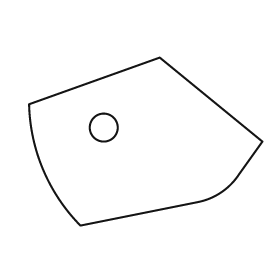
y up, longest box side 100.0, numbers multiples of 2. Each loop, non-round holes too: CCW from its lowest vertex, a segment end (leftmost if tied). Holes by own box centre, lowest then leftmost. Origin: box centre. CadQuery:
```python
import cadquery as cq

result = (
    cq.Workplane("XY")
    .moveTo(-28.0, -36.0)
    .lineTo(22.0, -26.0)
    .threePointArc((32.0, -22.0), (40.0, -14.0))
    .lineTo(50.0, 0.0)
    .lineTo(6.0, 36.0)
    .lineTo(-50.0, 16.0)
    .threePointArc((-44.0, -12.0), (-28.0, -36.0))
    .close()
    .moveTo(-18.0, 6.0)
    .circle(6.0)
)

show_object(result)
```